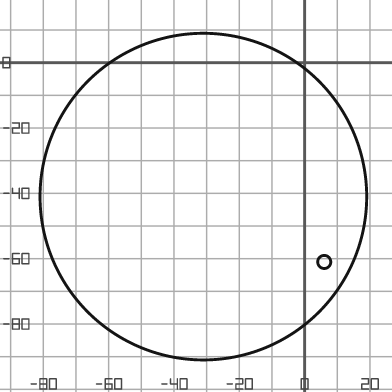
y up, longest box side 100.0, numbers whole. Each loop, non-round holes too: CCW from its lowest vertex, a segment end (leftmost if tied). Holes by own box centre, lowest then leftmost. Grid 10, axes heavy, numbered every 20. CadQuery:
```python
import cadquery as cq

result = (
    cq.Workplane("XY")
    .moveTo(-31.0, -41.0)
    .circle(50.0)
    .moveTo(6.0, -61.0)
    .circle(2.0)
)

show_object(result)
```